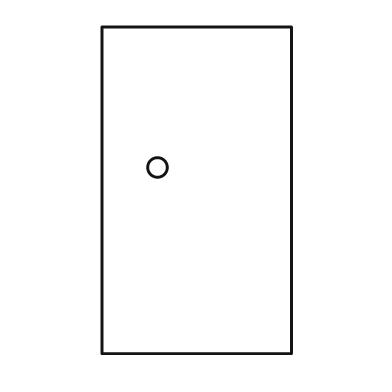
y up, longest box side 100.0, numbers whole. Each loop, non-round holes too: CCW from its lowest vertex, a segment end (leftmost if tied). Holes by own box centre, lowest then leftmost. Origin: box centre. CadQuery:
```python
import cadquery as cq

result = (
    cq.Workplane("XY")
    .moveTo(-29.0, -50.0)
    .lineTo(29.0, -50.0)
    .lineTo(29.0, 50.0)
    .lineTo(-29.0, 50.0)
    .close()
    .moveTo(-12.0, 7.0)
    .circle(3.0)
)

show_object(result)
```